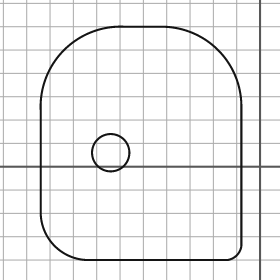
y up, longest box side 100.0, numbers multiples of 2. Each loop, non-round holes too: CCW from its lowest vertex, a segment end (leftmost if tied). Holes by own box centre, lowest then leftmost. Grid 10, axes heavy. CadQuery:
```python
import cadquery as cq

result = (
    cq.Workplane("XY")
    .moveTo(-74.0, -40.0)
    .lineTo(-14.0, -40.0)
    .threePointArc((-10.0, -38.0), (-8.0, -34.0))
    .lineTo(-8.0, 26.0)
    .threePointArc((-18.0, 50.0), (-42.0, 60.0))
    .lineTo(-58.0, 60.0)
    .threePointArc((-84.0, 50.0), (-94.0, 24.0))
    .lineTo(-94.0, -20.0)
    .threePointArc((-88.0, -34.0), (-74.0, -40.0))
    .close()
    .moveTo(-64.0, 6.0)
    .circle(8.0)
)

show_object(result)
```